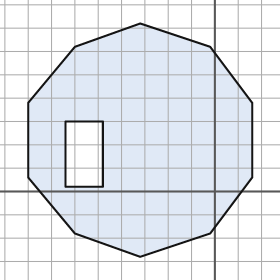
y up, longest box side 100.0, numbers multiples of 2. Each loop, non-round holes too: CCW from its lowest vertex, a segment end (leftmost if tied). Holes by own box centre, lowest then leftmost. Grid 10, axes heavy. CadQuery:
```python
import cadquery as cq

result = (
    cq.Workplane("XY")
    .moveTo(-32.0, -28.0)
    .lineTo(-2.0, -18.0)
    .lineTo(16.0, 6.0)
    .lineTo(16.0, 38.0)
    .lineTo(-2.0, 62.0)
    .lineTo(-32.0, 72.0)
    .lineTo(-60.0, 62.0)
    .lineTo(-80.0, 38.0)
    .lineTo(-80.0, 6.0)
    .lineTo(-60.0, -18.0)
    .close()
    .moveTo(-64.0, 2.0)
    .lineTo(-48.0, 2.0)
    .lineTo(-48.0, 30.0)
    .lineTo(-64.0, 30.0)
    .close()
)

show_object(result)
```